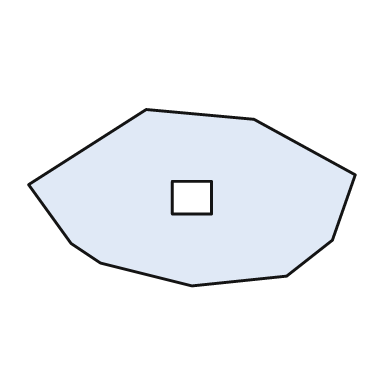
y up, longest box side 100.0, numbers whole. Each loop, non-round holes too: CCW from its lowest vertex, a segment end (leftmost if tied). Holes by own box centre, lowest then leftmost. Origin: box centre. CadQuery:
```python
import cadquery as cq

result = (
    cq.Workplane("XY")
    .moveTo(0.0, -27.0)
    .lineTo(29.0, -24.0)
    .lineTo(43.0, -13.0)
    .lineTo(50.0, 7.0)
    .lineTo(19.0, 24.0)
    .lineTo(-14.0, 27.0)
    .lineTo(-50.0, 4.0)
    .lineTo(-37.0, -14.0)
    .lineTo(-28.0, -20.0)
    .close()
    .moveTo(-6.0, -5.0)
    .lineTo(6.0, -5.0)
    .lineTo(6.0, 5.0)
    .lineTo(-6.0, 5.0)
    .close()
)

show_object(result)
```